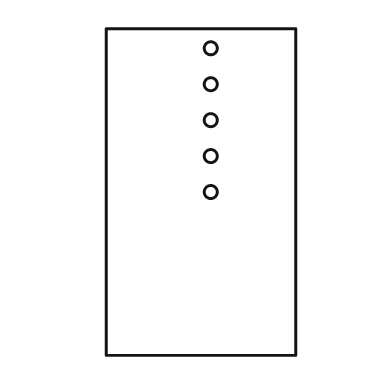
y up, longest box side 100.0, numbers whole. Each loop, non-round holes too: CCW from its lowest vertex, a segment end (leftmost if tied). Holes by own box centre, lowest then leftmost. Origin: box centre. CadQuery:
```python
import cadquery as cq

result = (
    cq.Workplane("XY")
    .moveTo(-29.0, -50.0)
    .lineTo(29.0, -50.0)
    .lineTo(29.0, 50.0)
    .lineTo(-29.0, 50.0)
    .close()
    .moveTo(3.0, 0.0)
    .circle(2.0)
    .moveTo(3.0, 11.0)
    .circle(2.0)
    .moveTo(3.0, 22.0)
    .circle(2.0)
    .moveTo(3.0, 33.0)
    .circle(2.0)
    .moveTo(3.0, 44.0)
    .circle(2.0)
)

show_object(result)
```